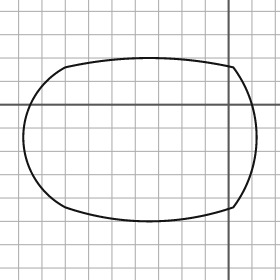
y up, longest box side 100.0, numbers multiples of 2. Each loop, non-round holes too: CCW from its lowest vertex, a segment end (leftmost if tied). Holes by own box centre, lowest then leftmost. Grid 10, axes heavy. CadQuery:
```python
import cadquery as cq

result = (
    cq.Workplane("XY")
    .moveTo(-70.0, -44.0)
    .threePointArc((-34.0, -50.0), (2.0, -44.0))
    .threePointArc((12.0, -14.0), (2.0, 16.0))
    .threePointArc((-34.0, 20.0), (-70.0, 16.0))
    .threePointArc((-88.0, -14.0), (-70.0, -44.0))
    .close()
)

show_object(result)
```